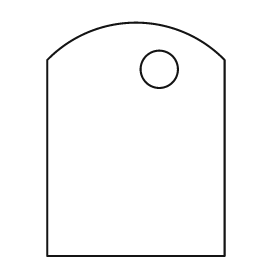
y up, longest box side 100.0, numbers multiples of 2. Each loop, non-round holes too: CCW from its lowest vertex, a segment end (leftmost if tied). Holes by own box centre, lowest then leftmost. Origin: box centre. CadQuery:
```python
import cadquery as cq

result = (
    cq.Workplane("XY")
    .moveTo(-38.0, -50.0)
    .lineTo(38.0, -50.0)
    .lineTo(38.0, 34.0)
    .threePointArc((0.0, 50.0), (-38.0, 34.0))
    .close()
    .moveTo(10.0, 30.0)
    .circle(8.0)
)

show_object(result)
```